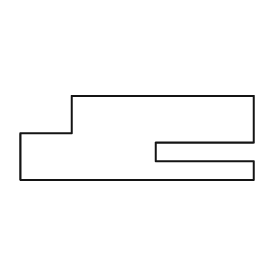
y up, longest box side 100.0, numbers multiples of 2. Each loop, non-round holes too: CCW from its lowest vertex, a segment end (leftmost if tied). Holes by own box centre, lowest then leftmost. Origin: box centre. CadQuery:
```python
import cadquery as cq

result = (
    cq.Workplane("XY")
    .moveTo(-50.0, -18.0)
    .lineTo(50.0, -18.0)
    .lineTo(50.0, -10.0)
    .lineTo(8.0, -10.0)
    .lineTo(8.0, -2.0)
    .lineTo(50.0, -2.0)
    .lineTo(50.0, 18.0)
    .lineTo(-28.0, 18.0)
    .lineTo(-28.0, 2.0)
    .lineTo(-50.0, 2.0)
    .close()
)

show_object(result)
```